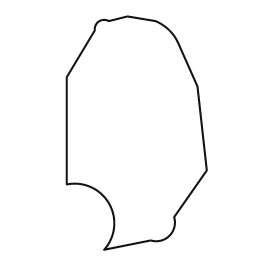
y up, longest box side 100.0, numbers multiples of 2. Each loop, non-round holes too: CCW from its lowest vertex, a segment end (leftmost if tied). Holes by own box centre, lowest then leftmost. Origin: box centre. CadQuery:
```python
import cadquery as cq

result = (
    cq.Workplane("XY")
    .moveTo(-14.0, -50.0)
    .lineTo(6.0, -46.0)
    .threePointArc((14.0, -44.0), (16.0, -36.0))
    .lineTo(30.0, -16.0)
    .lineTo(26.0, 20.0)
    .lineTo(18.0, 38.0)
    .threePointArc((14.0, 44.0), (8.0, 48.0))
    .lineTo(-4.0, 50.0)
    .lineTo(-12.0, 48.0)
    .threePointArc((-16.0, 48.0), (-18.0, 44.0))
    .lineTo(-30.0, 24.0)
    .lineTo(-30.0, -22.0)
    .threePointArc((-12.0, -30.0), (-14.0, -50.0))
    .close()
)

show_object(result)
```